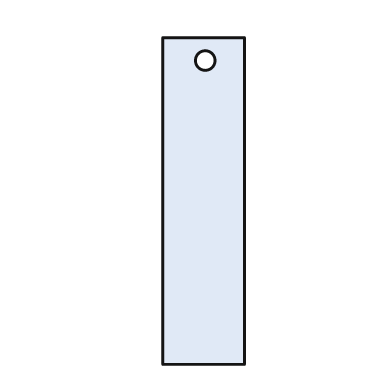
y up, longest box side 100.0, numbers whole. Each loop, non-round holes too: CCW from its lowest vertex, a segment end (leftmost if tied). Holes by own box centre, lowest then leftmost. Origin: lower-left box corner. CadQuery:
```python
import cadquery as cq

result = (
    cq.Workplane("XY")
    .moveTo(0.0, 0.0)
    .lineTo(25.0, 0.0)
    .lineTo(25.0, 100.0)
    .lineTo(0.0, 100.0)
    .close()
    .moveTo(13.0, 93.0)
    .circle(3.0)
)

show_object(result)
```